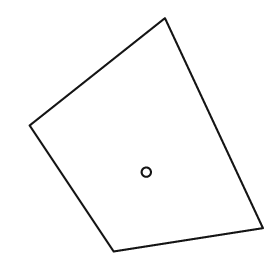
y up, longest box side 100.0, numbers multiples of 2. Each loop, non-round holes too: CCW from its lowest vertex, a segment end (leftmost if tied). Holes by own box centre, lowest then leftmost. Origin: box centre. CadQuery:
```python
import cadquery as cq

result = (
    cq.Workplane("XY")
    .moveTo(-14.0, -50.0)
    .lineTo(50.0, -40.0)
    .lineTo(8.0, 50.0)
    .lineTo(-50.0, 4.0)
    .close()
    .moveTo(0.0, -16.0)
    .circle(2.0)
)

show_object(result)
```